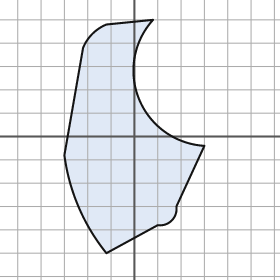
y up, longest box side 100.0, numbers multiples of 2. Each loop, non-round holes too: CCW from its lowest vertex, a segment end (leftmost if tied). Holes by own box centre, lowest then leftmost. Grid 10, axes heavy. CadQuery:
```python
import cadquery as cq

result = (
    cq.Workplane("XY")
    .moveTo(-12.0, -50.0)
    .lineTo(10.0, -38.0)
    .threePointArc((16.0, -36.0), (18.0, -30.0))
    .lineTo(30.0, -4.0)
    .threePointArc((2.0, 16.0), (8.0, 50.0))
    .lineTo(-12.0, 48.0)
    .threePointArc((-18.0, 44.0), (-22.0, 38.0))
    .lineTo(-30.0, -8.0)
    .threePointArc((-24.0, -30.0), (-12.0, -50.0))
    .close()
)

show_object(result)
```